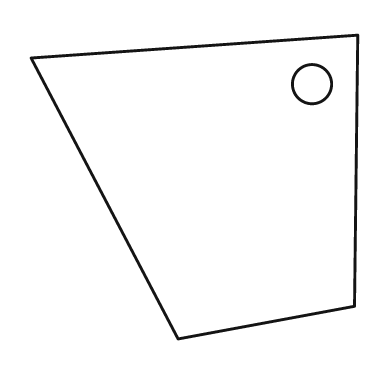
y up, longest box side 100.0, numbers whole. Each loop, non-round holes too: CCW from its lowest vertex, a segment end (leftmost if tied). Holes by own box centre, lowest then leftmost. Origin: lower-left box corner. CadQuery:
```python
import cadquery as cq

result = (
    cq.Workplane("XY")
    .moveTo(45.0, 0.0)
    .lineTo(99.0, 10.0)
    .lineTo(100.0, 93.0)
    .lineTo(0.0, 86.0)
    .close()
    .moveTo(86.0, 78.0)
    .circle(6.0)
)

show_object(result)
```